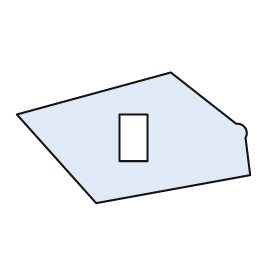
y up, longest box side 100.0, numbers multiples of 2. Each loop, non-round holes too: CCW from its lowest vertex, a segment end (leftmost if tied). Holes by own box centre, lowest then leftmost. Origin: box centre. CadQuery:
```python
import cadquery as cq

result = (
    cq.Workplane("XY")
    .moveTo(-16.0, -28.0)
    .lineTo(50.0, -16.0)
    .lineTo(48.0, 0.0)
    .threePointArc((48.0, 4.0), (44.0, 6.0))
    .lineTo(16.0, 28.0)
    .lineTo(-50.0, 10.0)
    .close()
    .moveTo(-6.0, -10.0)
    .lineTo(6.0, -10.0)
    .lineTo(6.0, 10.0)
    .lineTo(-6.0, 10.0)
    .close()
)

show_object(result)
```